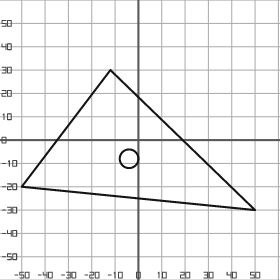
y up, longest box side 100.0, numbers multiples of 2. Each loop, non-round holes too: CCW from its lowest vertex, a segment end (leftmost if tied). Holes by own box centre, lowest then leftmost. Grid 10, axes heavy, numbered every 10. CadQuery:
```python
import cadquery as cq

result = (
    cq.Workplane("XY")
    .moveTo(50.0, -30.0)
    .lineTo(-12.0, 30.0)
    .lineTo(-50.0, -20.0)
    .close()
    .moveTo(-4.0, -8.0)
    .circle(4.0)
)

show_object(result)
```